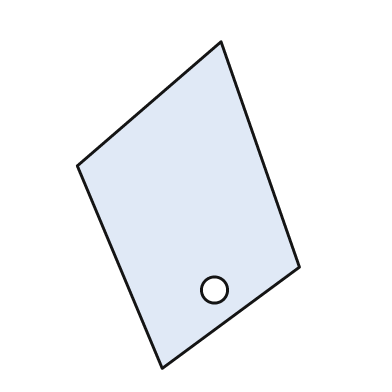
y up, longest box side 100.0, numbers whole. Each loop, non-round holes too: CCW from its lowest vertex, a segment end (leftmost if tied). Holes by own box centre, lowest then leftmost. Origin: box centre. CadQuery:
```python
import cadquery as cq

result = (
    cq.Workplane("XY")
    .moveTo(-8.0, -50.0)
    .lineTo(34.0, -19.0)
    .lineTo(10.0, 50.0)
    .lineTo(-34.0, 12.0)
    .close()
    .moveTo(8.0, -26.0)
    .circle(4.0)
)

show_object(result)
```